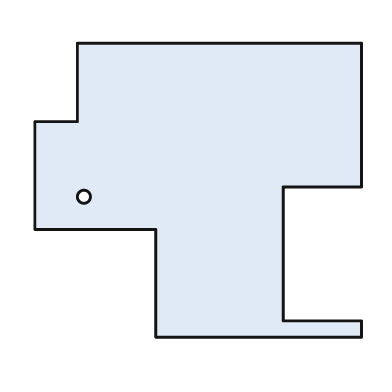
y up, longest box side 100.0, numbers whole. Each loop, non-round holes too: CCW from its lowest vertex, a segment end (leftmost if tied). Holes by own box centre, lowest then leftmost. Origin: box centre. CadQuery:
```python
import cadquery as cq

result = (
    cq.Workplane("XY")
    .moveTo(-13.0, -45.0)
    .lineTo(50.0, -45.0)
    .lineTo(50.0, -40.0)
    .lineTo(26.0, -40.0)
    .lineTo(26.0, 1.0)
    .lineTo(50.0, 1.0)
    .lineTo(50.0, 45.0)
    .lineTo(-37.0, 45.0)
    .lineTo(-37.0, 21.0)
    .lineTo(-50.0, 21.0)
    .lineTo(-50.0, -12.0)
    .lineTo(-13.0, -12.0)
    .close()
    .moveTo(-35.0, -2.0)
    .circle(2.0)
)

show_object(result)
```